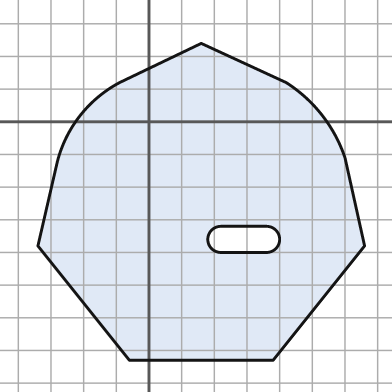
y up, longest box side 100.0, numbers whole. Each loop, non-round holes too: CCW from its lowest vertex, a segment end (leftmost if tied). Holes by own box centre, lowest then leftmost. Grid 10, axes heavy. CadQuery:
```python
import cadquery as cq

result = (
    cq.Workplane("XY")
    .moveTo(-6.0, -73.0)
    .lineTo(38.0, -73.0)
    .lineTo(66.0, -38.0)
    .lineTo(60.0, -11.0)
    .threePointArc((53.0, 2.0), (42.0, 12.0))
    .lineTo(16.0, 24.0)
    .lineTo(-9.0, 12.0)
    .threePointArc((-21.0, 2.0), (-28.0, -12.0))
    .lineTo(-34.0, -38.0)
    .close()
    .moveTo(22.0, -40.0)
    .lineTo(36.0, -40.0)
    .threePointArc((40.0, -36.0), (36.0, -32.0))
    .lineTo(22.0, -32.0)
    .threePointArc((18.0, -36.0), (22.0, -40.0))
    .close()
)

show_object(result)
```